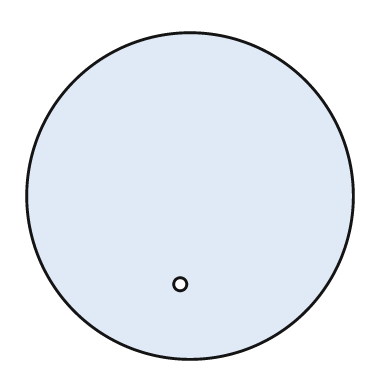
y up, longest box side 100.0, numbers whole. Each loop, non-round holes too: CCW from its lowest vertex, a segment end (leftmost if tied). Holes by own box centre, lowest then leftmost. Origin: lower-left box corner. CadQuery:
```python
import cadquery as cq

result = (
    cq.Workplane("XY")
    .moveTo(50.0, 50.0)
    .circle(50.0)
    .moveTo(47.0, 23.0)
    .circle(2.0)
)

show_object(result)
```